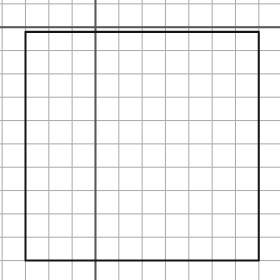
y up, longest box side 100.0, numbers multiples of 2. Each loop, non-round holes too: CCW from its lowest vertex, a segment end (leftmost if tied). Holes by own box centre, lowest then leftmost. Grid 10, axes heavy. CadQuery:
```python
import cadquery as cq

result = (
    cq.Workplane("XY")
    .moveTo(-30.0, -100.0)
    .lineTo(70.0, -100.0)
    .lineTo(70.0, -2.0)
    .lineTo(-30.0, -2.0)
    .close()
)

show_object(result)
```